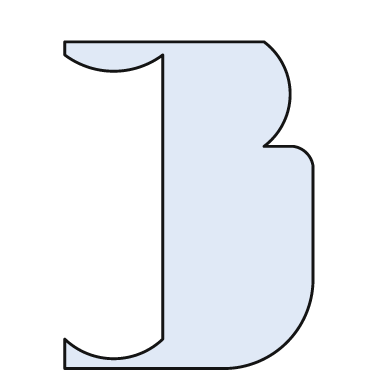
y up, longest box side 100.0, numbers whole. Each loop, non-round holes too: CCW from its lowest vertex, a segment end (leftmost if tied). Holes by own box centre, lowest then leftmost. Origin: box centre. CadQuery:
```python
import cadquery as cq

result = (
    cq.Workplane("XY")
    .moveTo(-38.0, -50.0)
    .lineTo(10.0, -50.0)
    .threePointArc((30.0, -42.0), (38.0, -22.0))
    .lineTo(38.0, 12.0)
    .threePointArc((36.0, 16.0), (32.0, 18.0))
    .lineTo(23.0, 18.0)
    .threePointArc((31.0, 34.0), (23.0, 50.0))
    .lineTo(-38.0, 50.0)
    .lineTo(-38.0, 46.0)
    .threePointArc((-23.0, 41.0), (-8.0, 46.0))
    .lineTo(-8.0, -41.0)
    .threePointArc((-23.0, -47.0), (-38.0, -41.0))
    .close()
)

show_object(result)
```